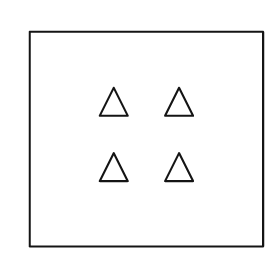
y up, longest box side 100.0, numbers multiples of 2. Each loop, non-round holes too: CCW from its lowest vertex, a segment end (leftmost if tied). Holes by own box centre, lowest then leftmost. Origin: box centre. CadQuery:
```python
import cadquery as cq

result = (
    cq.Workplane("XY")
    .moveTo(-50.0, -46.0)
    .lineTo(50.0, -46.0)
    .lineTo(50.0, 46.0)
    .lineTo(-50.0, 46.0)
    .close()
    .moveTo(-20.0, -18.0)
    .lineTo(-8.0, -18.0)
    .lineTo(-14.0, -6.0)
    .close()
    .moveTo(8.0, -18.0)
    .lineTo(20.0, -18.0)
    .lineTo(14.0, -6.0)
    .close()
    .moveTo(-20.0, 10.0)
    .lineTo(-8.0, 10.0)
    .lineTo(-14.0, 22.0)
    .close()
    .moveTo(8.0, 10.0)
    .lineTo(20.0, 10.0)
    .lineTo(14.0, 22.0)
    .close()
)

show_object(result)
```